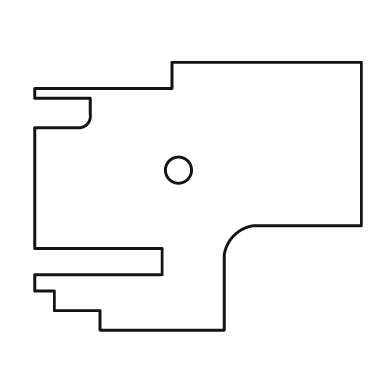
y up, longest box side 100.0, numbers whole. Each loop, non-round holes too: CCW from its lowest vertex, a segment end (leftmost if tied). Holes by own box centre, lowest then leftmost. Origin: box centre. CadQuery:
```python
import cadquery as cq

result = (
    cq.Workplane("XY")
    .moveTo(-30.0, -41.0)
    .lineTo(8.0, -41.0)
    .lineTo(8.0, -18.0)
    .threePointArc((11.0, -12.0), (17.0, -9.0))
    .lineTo(50.0, -9.0)
    .lineTo(50.0, 41.0)
    .lineTo(-8.0, 41.0)
    .lineTo(-8.0, 33.0)
    .lineTo(-50.0, 33.0)
    .lineTo(-50.0, 30.0)
    .lineTo(-33.0, 30.0)
    .lineTo(-33.0, 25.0)
    .threePointArc((-34.0, 22.0), (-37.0, 21.0))
    .lineTo(-50.0, 21.0)
    .lineTo(-50.0, -16.0)
    .lineTo(-11.0, -16.0)
    .lineTo(-11.0, -24.0)
    .lineTo(-50.0, -24.0)
    .lineTo(-50.0, -29.0)
    .lineTo(-44.0, -29.0)
    .lineTo(-44.0, -35.0)
    .lineTo(-30.0, -35.0)
    .close()
    .moveTo(-6.0, 8.0)
    .circle(4.0)
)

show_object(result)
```